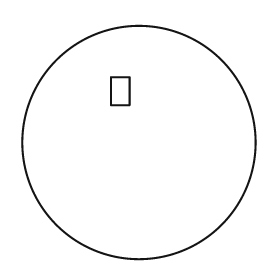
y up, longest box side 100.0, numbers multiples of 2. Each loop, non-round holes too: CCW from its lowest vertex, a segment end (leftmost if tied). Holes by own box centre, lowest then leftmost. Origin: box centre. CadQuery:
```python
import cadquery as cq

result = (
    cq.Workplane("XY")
    .moveTo(0.0, 0.0)
    .circle(50.0)
    .moveTo(-12.0, 16.0)
    .lineTo(-4.0, 16.0)
    .lineTo(-4.0, 28.0)
    .lineTo(-12.0, 28.0)
    .close()
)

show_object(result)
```